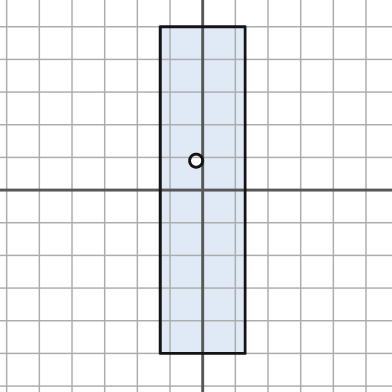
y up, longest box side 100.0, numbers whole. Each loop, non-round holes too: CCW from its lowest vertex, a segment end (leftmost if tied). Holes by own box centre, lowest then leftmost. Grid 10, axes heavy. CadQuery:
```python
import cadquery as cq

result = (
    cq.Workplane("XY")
    .moveTo(-13.0, -50.0)
    .lineTo(13.0, -50.0)
    .lineTo(13.0, 50.0)
    .lineTo(-13.0, 50.0)
    .close()
    .moveTo(-2.0, 9.0)
    .circle(2.0)
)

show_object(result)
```